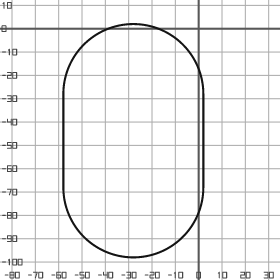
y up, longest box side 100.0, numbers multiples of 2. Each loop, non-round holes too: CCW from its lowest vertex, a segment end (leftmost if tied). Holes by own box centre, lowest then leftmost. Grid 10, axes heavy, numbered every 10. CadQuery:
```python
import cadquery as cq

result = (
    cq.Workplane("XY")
    .moveTo(-58.0, -68.0)
    .threePointArc((-28.0, -98.0), (2.0, -68.0))
    .lineTo(2.0, -28.0)
    .threePointArc((-28.0, 2.0), (-58.0, -28.0))
    .close()
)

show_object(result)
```